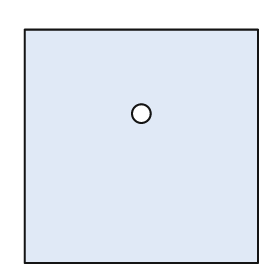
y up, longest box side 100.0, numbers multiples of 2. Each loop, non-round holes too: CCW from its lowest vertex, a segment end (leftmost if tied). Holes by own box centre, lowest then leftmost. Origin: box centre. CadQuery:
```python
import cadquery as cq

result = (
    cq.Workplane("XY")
    .moveTo(-50.0, -50.0)
    .lineTo(50.0, -50.0)
    .lineTo(50.0, 50.0)
    .lineTo(-50.0, 50.0)
    .close()
    .moveTo(0.0, 14.0)
    .circle(4.0)
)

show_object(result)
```